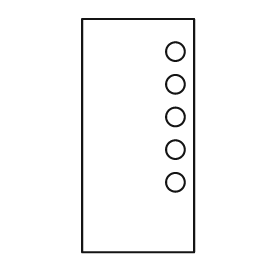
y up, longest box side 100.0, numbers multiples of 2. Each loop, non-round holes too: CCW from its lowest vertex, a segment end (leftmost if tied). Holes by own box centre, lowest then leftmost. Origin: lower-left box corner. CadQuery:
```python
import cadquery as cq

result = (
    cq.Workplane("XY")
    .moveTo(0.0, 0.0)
    .lineTo(48.0, 0.0)
    .lineTo(48.0, 100.0)
    .lineTo(0.0, 100.0)
    .close()
    .moveTo(40.0, 30.0)
    .circle(4.0)
    .moveTo(40.0, 44.0)
    .circle(4.0)
    .moveTo(40.0, 58.0)
    .circle(4.0)
    .moveTo(40.0, 72.0)
    .circle(4.0)
    .moveTo(40.0, 86.0)
    .circle(4.0)
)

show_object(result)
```